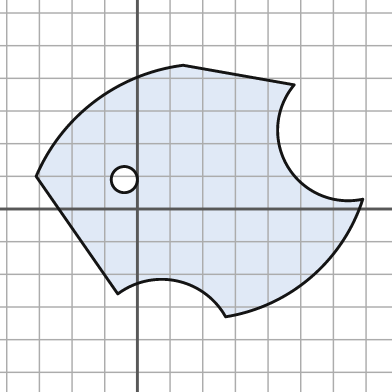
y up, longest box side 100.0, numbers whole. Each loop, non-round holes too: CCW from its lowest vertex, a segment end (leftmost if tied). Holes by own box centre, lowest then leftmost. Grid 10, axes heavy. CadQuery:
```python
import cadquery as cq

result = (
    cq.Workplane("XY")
    .moveTo(27.0, -33.0)
    .threePointArc((53.0, -21.0), (69.0, 3.0))
    .threePointArc((46.0, 13.0), (48.0, 38.0))
    .lineTo(14.0, 44.0)
    .threePointArc((-13.0, 33.0), (-31.0, 10.0))
    .lineTo(-6.0, -26.0)
    .threePointArc((12.0, -22.0), (27.0, -33.0))
    .close()
    .moveTo(-4.0, 9.0)
    .circle(4.0)
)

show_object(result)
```